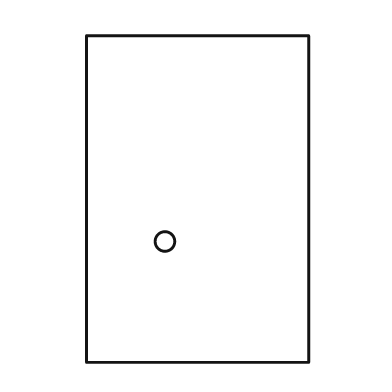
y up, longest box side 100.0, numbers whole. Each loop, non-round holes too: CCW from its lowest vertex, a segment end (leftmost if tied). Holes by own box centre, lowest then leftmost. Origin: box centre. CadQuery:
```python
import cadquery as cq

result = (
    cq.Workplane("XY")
    .moveTo(-34.0, -50.0)
    .lineTo(34.0, -50.0)
    .lineTo(34.0, 50.0)
    .lineTo(-34.0, 50.0)
    .close()
    .moveTo(-10.0, -13.0)
    .circle(3.0)
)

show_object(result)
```